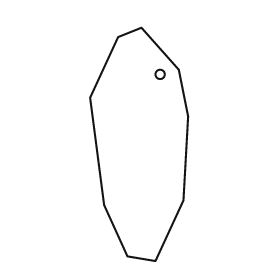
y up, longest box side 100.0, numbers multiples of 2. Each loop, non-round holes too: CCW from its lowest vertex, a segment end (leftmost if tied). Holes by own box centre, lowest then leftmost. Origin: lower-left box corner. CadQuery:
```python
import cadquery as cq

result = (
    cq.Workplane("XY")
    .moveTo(28.0, 0.0)
    .lineTo(40.0, 26.0)
    .lineTo(42.0, 62.0)
    .lineTo(38.0, 82.0)
    .lineTo(22.0, 100.0)
    .lineTo(12.0, 96.0)
    .lineTo(0.0, 70.0)
    .lineTo(6.0, 24.0)
    .lineTo(16.0, 2.0)
    .close()
    .moveTo(30.0, 80.0)
    .circle(2.0)
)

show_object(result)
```